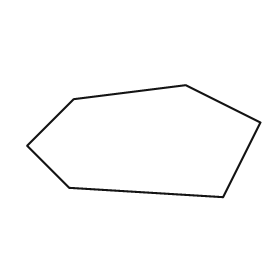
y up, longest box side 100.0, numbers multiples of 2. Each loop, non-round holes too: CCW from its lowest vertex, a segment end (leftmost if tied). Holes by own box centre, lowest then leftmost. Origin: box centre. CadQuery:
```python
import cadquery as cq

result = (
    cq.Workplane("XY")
    .moveTo(34.0, -24.0)
    .lineTo(50.0, 8.0)
    .lineTo(18.0, 24.0)
    .lineTo(-30.0, 18.0)
    .lineTo(-50.0, -2.0)
    .lineTo(-32.0, -20.0)
    .close()
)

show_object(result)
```